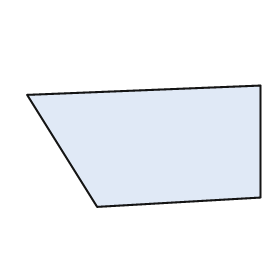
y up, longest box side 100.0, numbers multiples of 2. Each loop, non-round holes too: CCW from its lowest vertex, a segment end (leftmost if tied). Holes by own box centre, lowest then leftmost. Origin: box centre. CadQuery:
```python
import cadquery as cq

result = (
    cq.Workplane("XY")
    .moveTo(-20.0, -26.0)
    .lineTo(50.0, -22.0)
    .lineTo(50.0, 26.0)
    .lineTo(-50.0, 22.0)
    .close()
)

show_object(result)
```